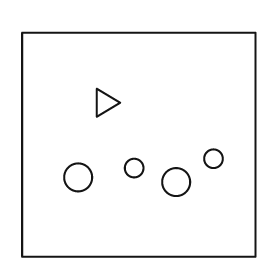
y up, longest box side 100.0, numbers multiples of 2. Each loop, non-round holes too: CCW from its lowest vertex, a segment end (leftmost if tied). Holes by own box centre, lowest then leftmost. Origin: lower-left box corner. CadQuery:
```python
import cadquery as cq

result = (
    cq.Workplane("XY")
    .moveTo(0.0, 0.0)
    .lineTo(100.0, 0.0)
    .lineTo(100.0, 96.0)
    .lineTo(0.0, 96.0)
    .close()
    .moveTo(66.0, 32.0)
    .circle(6.0)
    .moveTo(24.0, 34.0)
    .circle(6.0)
    .moveTo(48.0, 38.0)
    .circle(4.0)
    .moveTo(82.0, 42.0)
    .circle(4.0)
    .moveTo(32.0, 60.0)
    .lineTo(42.0, 66.0)
    .lineTo(32.0, 72.0)
    .close()
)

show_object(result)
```